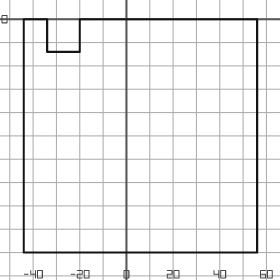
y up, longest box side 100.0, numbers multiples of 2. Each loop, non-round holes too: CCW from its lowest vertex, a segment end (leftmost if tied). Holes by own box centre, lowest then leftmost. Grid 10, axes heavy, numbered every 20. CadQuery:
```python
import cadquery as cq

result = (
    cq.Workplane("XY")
    .moveTo(-44.0, -100.0)
    .lineTo(56.0, -100.0)
    .lineTo(56.0, 0.0)
    .lineTo(-20.0, 0.0)
    .lineTo(-20.0, -14.0)
    .lineTo(-34.0, -14.0)
    .lineTo(-34.0, 0.0)
    .lineTo(-44.0, 0.0)
    .close()
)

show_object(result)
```